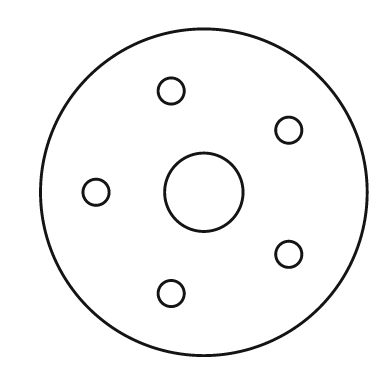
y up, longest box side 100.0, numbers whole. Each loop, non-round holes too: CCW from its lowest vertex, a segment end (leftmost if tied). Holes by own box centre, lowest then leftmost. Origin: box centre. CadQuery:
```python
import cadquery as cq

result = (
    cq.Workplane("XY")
    .moveTo(0.0, 0.0)
    .circle(50.0)
    .moveTo(-10.0, -31.0)
    .circle(4.0)
    .moveTo(26.0, -19.0)
    .circle(4.0)
    .moveTo(-33.0, 0.0)
    .circle(4.0)
    .moveTo(0.0, 0.0)
    .circle(12.0)
    .moveTo(26.0, 19.0)
    .circle(4.0)
    .moveTo(-10.0, 31.0)
    .circle(4.0)
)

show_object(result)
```